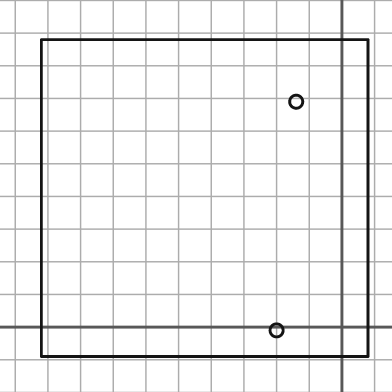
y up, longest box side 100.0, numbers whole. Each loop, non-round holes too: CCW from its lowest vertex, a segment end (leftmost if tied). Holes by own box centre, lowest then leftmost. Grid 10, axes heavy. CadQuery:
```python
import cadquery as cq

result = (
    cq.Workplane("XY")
    .moveTo(-92.0, -9.0)
    .lineTo(8.0, -9.0)
    .lineTo(8.0, 88.0)
    .lineTo(-92.0, 88.0)
    .close()
    .moveTo(-20.0, -1.0)
    .circle(2.0)
    .moveTo(-14.0, 69.0)
    .circle(2.0)
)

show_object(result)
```